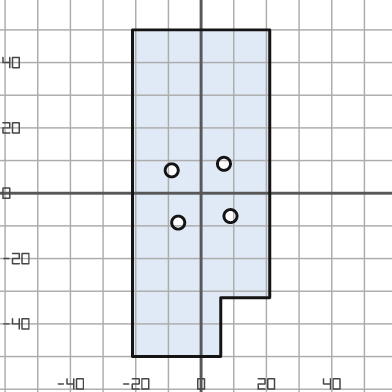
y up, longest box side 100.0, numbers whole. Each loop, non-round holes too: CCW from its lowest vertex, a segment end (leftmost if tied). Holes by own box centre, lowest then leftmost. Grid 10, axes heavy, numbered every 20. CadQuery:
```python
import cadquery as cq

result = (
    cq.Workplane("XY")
    .moveTo(-21.0, -50.0)
    .lineTo(6.0, -50.0)
    .lineTo(6.0, -32.0)
    .lineTo(21.0, -32.0)
    .lineTo(21.0, 50.0)
    .lineTo(-21.0, 50.0)
    .close()
    .moveTo(-7.0, -9.0)
    .circle(2.0)
    .moveTo(9.0, -7.0)
    .circle(2.0)
    .moveTo(-9.0, 7.0)
    .circle(2.0)
    .moveTo(7.0, 9.0)
    .circle(2.0)
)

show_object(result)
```